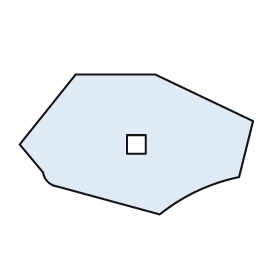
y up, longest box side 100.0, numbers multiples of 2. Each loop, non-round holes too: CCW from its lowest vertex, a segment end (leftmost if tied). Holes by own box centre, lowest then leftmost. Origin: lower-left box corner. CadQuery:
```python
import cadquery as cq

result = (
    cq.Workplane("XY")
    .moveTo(60.0, 0.0)
    .threePointArc((76.0, 10.0), (94.0, 16.0))
    .lineTo(100.0, 40.0)
    .lineTo(58.0, 60.0)
    .lineTo(24.0, 60.0)
    .lineTo(0.0, 30.0)
    .lineTo(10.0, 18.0)
    .threePointArc((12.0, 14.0), (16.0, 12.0))
    .close()
    .moveTo(46.0, 26.0)
    .lineTo(54.0, 26.0)
    .lineTo(54.0, 34.0)
    .lineTo(46.0, 34.0)
    .close()
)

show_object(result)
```